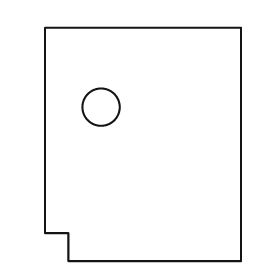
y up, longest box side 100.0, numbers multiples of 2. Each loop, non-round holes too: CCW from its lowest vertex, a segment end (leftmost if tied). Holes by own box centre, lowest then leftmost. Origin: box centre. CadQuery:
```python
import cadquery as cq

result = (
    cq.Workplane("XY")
    .moveTo(-32.0, -50.0)
    .lineTo(42.0, -50.0)
    .lineTo(42.0, 50.0)
    .lineTo(-42.0, 50.0)
    .lineTo(-42.0, -38.0)
    .lineTo(-32.0, -38.0)
    .close()
    .moveTo(-18.0, 16.0)
    .circle(8.0)
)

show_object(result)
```